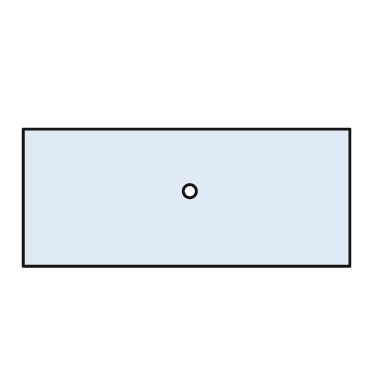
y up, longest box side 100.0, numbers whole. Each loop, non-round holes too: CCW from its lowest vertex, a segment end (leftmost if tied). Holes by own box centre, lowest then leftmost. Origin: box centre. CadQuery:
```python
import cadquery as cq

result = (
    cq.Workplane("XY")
    .moveTo(-50.0, -21.0)
    .lineTo(50.0, -21.0)
    .lineTo(50.0, 21.0)
    .lineTo(-50.0, 21.0)
    .close()
    .moveTo(1.0, 2.0)
    .circle(2.0)
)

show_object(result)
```